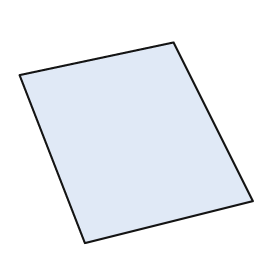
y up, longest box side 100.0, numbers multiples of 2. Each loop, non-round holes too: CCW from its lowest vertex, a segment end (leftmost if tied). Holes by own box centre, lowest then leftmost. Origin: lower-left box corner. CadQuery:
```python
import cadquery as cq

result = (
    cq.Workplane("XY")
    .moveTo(28.0, 0.0)
    .lineTo(100.0, 18.0)
    .lineTo(66.0, 86.0)
    .lineTo(0.0, 72.0)
    .close()
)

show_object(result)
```